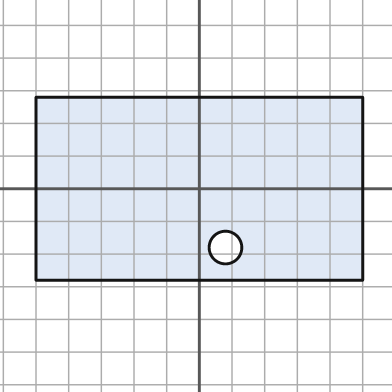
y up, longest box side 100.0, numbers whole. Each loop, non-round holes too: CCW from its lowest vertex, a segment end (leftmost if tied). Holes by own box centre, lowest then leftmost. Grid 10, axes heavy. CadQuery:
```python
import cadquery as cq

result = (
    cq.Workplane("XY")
    .moveTo(-50.0, -28.0)
    .lineTo(50.0, -28.0)
    .lineTo(50.0, 28.0)
    .lineTo(-50.0, 28.0)
    .close()
    .moveTo(8.0, -18.0)
    .circle(5.0)
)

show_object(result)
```